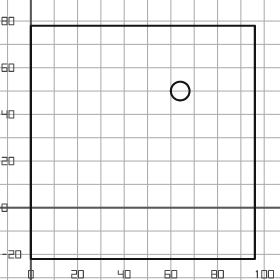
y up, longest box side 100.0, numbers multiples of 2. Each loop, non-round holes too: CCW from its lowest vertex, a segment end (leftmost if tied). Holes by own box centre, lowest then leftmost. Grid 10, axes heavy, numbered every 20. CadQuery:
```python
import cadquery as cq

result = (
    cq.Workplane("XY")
    .moveTo(0.0, -22.0)
    .lineTo(96.0, -22.0)
    .lineTo(96.0, 78.0)
    .lineTo(0.0, 78.0)
    .close()
    .moveTo(64.0, 50.0)
    .circle(4.0)
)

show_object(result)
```